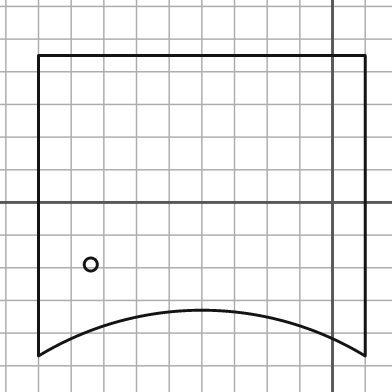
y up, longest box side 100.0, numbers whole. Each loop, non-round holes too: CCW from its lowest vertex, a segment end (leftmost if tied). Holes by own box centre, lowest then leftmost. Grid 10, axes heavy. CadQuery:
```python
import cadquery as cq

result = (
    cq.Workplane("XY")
    .moveTo(-90.0, -47.0)
    .threePointArc((-40.0, -33.0), (10.0, -47.0))
    .lineTo(10.0, 45.0)
    .lineTo(-90.0, 45.0)
    .close()
    .moveTo(-74.0, -19.0)
    .circle(2.0)
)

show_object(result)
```